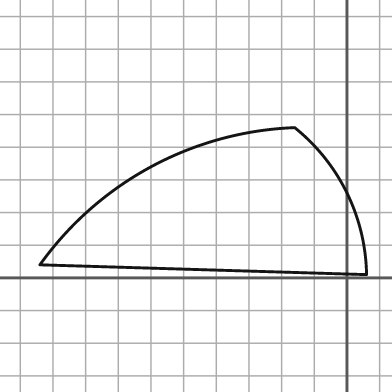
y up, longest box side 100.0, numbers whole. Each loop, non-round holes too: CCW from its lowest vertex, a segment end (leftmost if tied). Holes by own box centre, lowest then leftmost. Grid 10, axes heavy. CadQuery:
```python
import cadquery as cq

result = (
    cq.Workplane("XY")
    .moveTo(6.0, 1.0)
    .threePointArc((0.0, 26.0), (-16.0, 46.0))
    .threePointArc((-60.0, 34.0), (-94.0, 4.0))
    .close()
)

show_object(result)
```